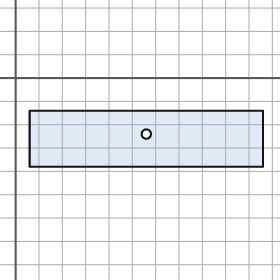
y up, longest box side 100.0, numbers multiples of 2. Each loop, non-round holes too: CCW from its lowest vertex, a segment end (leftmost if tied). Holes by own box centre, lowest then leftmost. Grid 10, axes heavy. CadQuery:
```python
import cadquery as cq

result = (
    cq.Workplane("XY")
    .moveTo(6.0, -38.0)
    .lineTo(106.0, -38.0)
    .lineTo(106.0, -14.0)
    .lineTo(6.0, -14.0)
    .close()
    .moveTo(56.0, -24.0)
    .circle(2.0)
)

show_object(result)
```